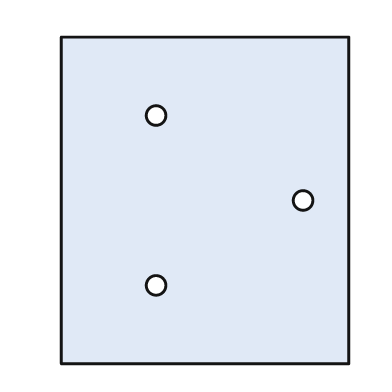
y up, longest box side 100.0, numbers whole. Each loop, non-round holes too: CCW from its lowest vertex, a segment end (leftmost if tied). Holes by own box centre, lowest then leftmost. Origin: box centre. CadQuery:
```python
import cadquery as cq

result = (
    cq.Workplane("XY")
    .moveTo(-44.0, -50.0)
    .lineTo(44.0, -50.0)
    .lineTo(44.0, 50.0)
    .lineTo(-44.0, 50.0)
    .close()
    .moveTo(-15.0, -26.0)
    .circle(3.0)
    .moveTo(30.0, 0.0)
    .circle(3.0)
    .moveTo(-15.0, 26.0)
    .circle(3.0)
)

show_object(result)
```